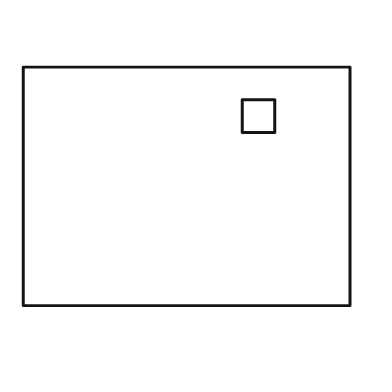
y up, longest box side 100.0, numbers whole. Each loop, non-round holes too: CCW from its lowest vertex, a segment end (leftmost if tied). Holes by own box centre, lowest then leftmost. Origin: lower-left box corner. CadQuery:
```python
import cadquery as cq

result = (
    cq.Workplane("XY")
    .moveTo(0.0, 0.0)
    .lineTo(100.0, 0.0)
    .lineTo(100.0, 73.0)
    .lineTo(0.0, 73.0)
    .close()
    .moveTo(67.0, 53.0)
    .lineTo(77.0, 53.0)
    .lineTo(77.0, 63.0)
    .lineTo(67.0, 63.0)
    .close()
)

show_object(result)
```